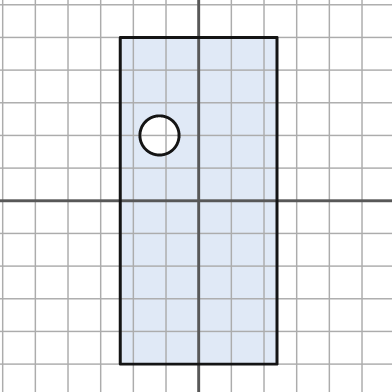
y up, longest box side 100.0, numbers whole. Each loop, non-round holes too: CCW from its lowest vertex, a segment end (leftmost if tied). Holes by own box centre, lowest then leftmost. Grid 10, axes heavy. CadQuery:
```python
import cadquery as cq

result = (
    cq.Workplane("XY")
    .moveTo(-24.0, -50.0)
    .lineTo(24.0, -50.0)
    .lineTo(24.0, 50.0)
    .lineTo(-24.0, 50.0)
    .close()
    .moveTo(-12.0, 20.0)
    .circle(6.0)
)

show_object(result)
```